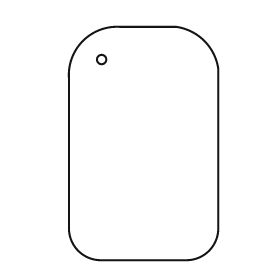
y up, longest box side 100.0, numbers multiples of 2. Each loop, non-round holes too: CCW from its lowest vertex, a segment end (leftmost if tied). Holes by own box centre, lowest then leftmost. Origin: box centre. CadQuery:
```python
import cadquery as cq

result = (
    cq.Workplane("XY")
    .moveTo(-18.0, -50.0)
    .lineTo(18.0, -50.0)
    .threePointArc((28.0, -46.0), (32.0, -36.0))
    .lineTo(32.0, 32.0)
    .threePointArc((26.0, 44.0), (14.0, 50.0))
    .lineTo(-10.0, 50.0)
    .threePointArc((-26.0, 44.0), (-32.0, 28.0))
    .lineTo(-32.0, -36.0)
    .threePointArc((-28.0, -46.0), (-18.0, -50.0))
    .close()
    .moveTo(-18.0, 36.0)
    .circle(2.0)
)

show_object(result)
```